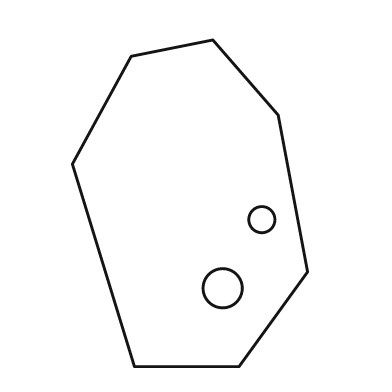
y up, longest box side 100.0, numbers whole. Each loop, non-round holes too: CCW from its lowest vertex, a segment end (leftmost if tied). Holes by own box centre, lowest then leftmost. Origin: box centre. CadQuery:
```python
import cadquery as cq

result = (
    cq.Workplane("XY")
    .moveTo(-17.0, -50.0)
    .lineTo(15.0, -50.0)
    .lineTo(36.0, -21.0)
    .lineTo(27.0, 27.0)
    .lineTo(7.0, 50.0)
    .lineTo(-18.0, 45.0)
    .lineTo(-36.0, 12.0)
    .close()
    .moveTo(10.0, -26.0)
    .circle(6.0)
    .moveTo(22.0, -5.0)
    .circle(4.0)
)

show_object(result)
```